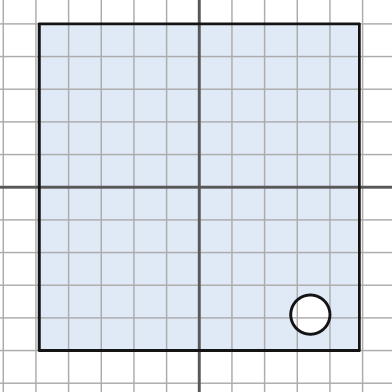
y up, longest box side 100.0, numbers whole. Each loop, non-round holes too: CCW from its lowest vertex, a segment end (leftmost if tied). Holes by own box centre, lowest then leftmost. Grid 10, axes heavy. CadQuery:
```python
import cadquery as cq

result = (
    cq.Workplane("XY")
    .moveTo(-49.0, -50.0)
    .lineTo(49.0, -50.0)
    .lineTo(49.0, 50.0)
    .lineTo(-49.0, 50.0)
    .close()
    .moveTo(34.0, -39.0)
    .circle(6.0)
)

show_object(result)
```